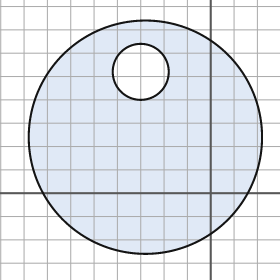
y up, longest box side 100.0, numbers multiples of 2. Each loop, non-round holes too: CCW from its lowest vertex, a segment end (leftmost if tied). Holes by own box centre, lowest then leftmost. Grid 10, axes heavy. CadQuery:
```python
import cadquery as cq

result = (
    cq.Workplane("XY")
    .moveTo(-28.0, 24.0)
    .circle(50.0)
    .moveTo(-30.0, 52.0)
    .circle(12.0)
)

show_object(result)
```